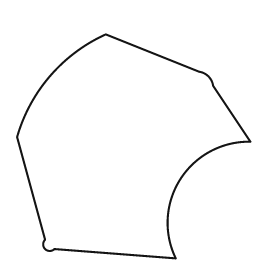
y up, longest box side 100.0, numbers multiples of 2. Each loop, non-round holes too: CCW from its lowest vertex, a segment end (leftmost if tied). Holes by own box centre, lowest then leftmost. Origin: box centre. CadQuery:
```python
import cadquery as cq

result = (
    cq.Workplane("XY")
    .moveTo(18.0, -48.0)
    .threePointArc((20.0, -14.0), (50.0, 2.0))
    .lineTo(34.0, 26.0)
    .threePointArc((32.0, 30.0), (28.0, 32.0))
    .lineTo(-12.0, 48.0)
    .threePointArc((-36.0, 30.0), (-50.0, 4.0))
    .lineTo(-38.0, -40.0)
    .threePointArc((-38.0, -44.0), (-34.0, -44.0))
    .close()
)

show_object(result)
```